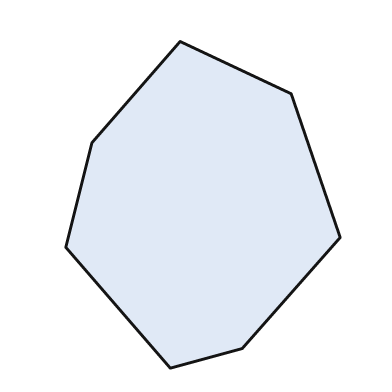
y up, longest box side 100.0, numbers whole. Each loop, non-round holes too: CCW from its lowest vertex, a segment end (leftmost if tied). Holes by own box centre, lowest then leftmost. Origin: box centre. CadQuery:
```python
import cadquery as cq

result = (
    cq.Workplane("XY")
    .moveTo(-10.0, -50.0)
    .lineTo(12.0, -44.0)
    .lineTo(42.0, -10.0)
    .lineTo(27.0, 34.0)
    .lineTo(-7.0, 50.0)
    .lineTo(-34.0, 19.0)
    .lineTo(-42.0, -13.0)
    .close()
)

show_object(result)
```